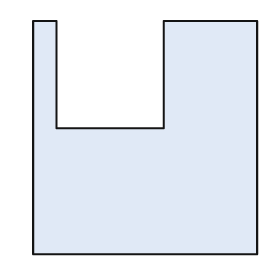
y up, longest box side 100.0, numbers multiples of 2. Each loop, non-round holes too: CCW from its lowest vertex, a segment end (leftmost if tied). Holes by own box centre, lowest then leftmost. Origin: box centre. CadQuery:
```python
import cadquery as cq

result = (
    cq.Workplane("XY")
    .moveTo(-48.0, -50.0)
    .lineTo(48.0, -50.0)
    .lineTo(48.0, 50.0)
    .lineTo(8.0, 50.0)
    .lineTo(8.0, 4.0)
    .lineTo(-38.0, 4.0)
    .lineTo(-38.0, 50.0)
    .lineTo(-48.0, 50.0)
    .close()
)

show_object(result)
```